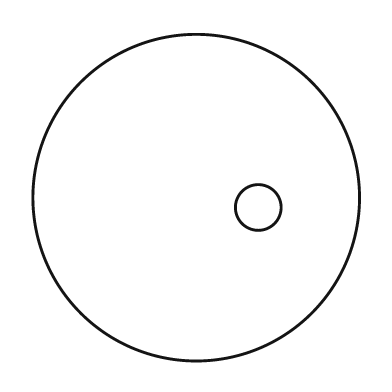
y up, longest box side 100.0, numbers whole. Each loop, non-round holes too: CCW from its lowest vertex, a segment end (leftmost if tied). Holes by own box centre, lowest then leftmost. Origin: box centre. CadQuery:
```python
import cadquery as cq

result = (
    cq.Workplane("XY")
    .moveTo(0.0, 0.0)
    .circle(50.0)
    .moveTo(19.0, -3.0)
    .circle(7.0)
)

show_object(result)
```